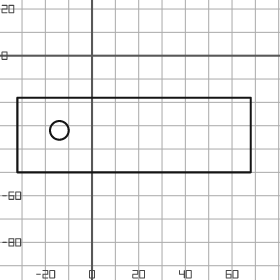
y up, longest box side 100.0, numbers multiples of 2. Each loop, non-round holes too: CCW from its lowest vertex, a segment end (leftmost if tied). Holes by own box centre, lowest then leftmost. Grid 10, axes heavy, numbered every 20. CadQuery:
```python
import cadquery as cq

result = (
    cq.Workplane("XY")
    .moveTo(-32.0, -50.0)
    .lineTo(68.0, -50.0)
    .lineTo(68.0, -18.0)
    .lineTo(-32.0, -18.0)
    .close()
    .moveTo(-14.0, -32.0)
    .circle(4.0)
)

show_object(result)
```